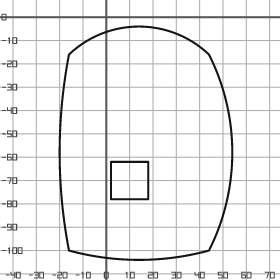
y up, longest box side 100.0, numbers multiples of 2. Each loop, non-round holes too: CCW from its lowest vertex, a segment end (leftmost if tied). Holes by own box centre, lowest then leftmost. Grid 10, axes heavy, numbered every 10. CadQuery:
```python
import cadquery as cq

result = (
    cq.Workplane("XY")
    .moveTo(-16.0, -100.0)
    .threePointArc((14.0, -104.0), (44.0, -100.0))
    .threePointArc((54.0, -58.0), (44.0, -16.0))
    .threePointArc((14.0, -4.0), (-16.0, -16.0))
    .threePointArc((-20.0, -58.0), (-16.0, -100.0))
    .close()
    .moveTo(2.0, -78.0)
    .lineTo(18.0, -78.0)
    .lineTo(18.0, -62.0)
    .lineTo(2.0, -62.0)
    .close()
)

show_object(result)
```